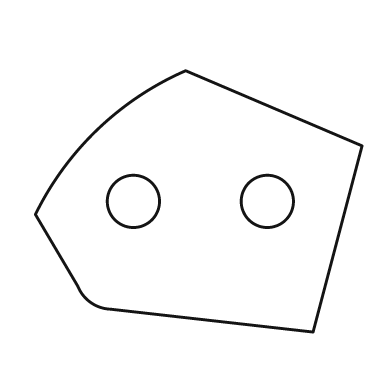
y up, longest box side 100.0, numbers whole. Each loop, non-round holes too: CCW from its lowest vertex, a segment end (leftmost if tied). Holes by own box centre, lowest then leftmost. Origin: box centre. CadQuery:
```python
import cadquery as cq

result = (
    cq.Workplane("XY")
    .moveTo(35.0, -40.0)
    .lineTo(50.0, 17.0)
    .lineTo(-4.0, 40.0)
    .threePointArc((-31.0, 22.0), (-50.0, -4.0))
    .lineTo(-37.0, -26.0)
    .threePointArc((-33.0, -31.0), (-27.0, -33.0))
    .close()
    .moveTo(-20.0, 0.0)
    .circle(8.0)
    .moveTo(21.0, 0.0)
    .circle(8.0)
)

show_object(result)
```